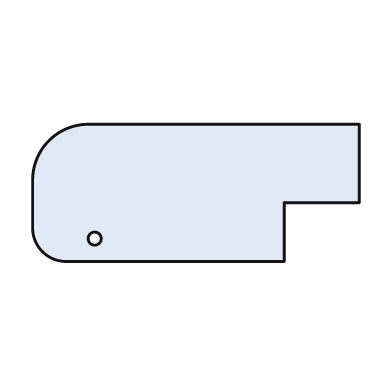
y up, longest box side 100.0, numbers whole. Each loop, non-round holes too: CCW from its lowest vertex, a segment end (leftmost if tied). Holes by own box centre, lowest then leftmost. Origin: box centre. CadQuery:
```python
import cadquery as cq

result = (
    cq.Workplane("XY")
    .moveTo(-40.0, -21.0)
    .lineTo(27.0, -21.0)
    .lineTo(27.0, -3.0)
    .lineTo(50.0, -3.0)
    .lineTo(50.0, 21.0)
    .lineTo(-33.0, 21.0)
    .threePointArc((-45.0, 16.0), (-50.0, 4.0))
    .lineTo(-50.0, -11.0)
    .threePointArc((-47.0, -18.0), (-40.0, -21.0))
    .close()
    .moveTo(-31.0, -14.0)
    .circle(2.0)
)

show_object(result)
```